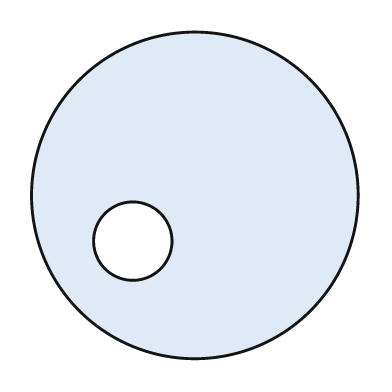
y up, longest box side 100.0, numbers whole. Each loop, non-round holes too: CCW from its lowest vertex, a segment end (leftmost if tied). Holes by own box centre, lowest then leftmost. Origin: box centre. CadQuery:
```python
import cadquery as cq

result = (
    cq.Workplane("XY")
    .moveTo(0.0, 0.0)
    .circle(50.0)
    .moveTo(-19.0, -14.0)
    .circle(12.0)
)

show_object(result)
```